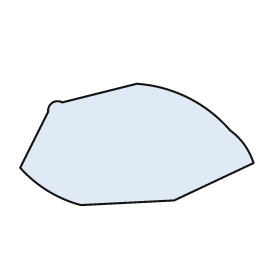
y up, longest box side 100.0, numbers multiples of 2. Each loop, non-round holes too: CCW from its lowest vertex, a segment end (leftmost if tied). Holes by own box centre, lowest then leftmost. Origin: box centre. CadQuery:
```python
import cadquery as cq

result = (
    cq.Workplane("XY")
    .moveTo(-24.0, -26.0)
    .lineTo(16.0, -24.0)
    .lineTo(50.0, -8.0)
    .threePointArc((46.0, 0.0), (40.0, 6.0))
    .threePointArc((22.0, 20.0), (0.0, 26.0))
    .lineTo(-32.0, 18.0)
    .threePointArc((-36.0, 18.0), (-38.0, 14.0))
    .lineTo(-50.0, -10.0)
    .threePointArc((-38.0, -20.0), (-24.0, -26.0))
    .close()
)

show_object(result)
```